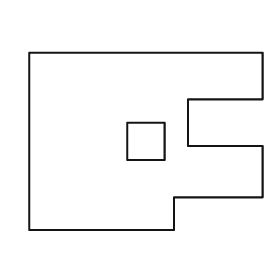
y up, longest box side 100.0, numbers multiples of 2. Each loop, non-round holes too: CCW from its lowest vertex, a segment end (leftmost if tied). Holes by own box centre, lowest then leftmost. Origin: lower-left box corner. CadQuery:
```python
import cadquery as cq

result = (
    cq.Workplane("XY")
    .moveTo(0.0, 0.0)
    .lineTo(62.0, 0.0)
    .lineTo(62.0, 14.0)
    .lineTo(100.0, 14.0)
    .lineTo(100.0, 36.0)
    .lineTo(68.0, 36.0)
    .lineTo(68.0, 56.0)
    .lineTo(100.0, 56.0)
    .lineTo(100.0, 76.0)
    .lineTo(0.0, 76.0)
    .close()
    .moveTo(42.0, 30.0)
    .lineTo(58.0, 30.0)
    .lineTo(58.0, 46.0)
    .lineTo(42.0, 46.0)
    .close()
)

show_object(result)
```